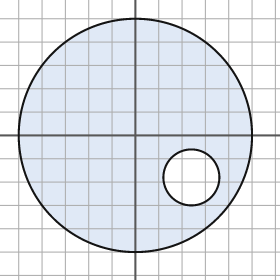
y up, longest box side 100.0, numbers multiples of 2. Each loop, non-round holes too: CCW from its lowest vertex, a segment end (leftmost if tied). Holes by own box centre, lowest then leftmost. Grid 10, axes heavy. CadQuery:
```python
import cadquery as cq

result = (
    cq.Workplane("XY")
    .moveTo(0.0, 0.0)
    .circle(50.0)
    .moveTo(24.0, -18.0)
    .circle(12.0)
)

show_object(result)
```